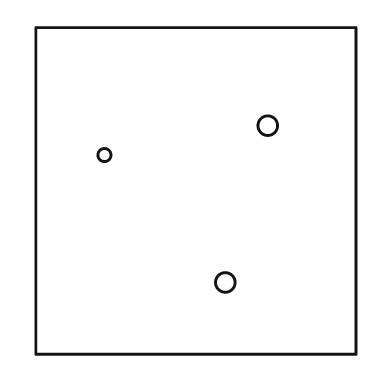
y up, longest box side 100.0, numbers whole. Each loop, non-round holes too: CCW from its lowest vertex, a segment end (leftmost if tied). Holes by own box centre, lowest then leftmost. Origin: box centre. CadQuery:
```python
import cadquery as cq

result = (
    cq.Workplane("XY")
    .moveTo(-49.0, -50.0)
    .lineTo(49.0, -50.0)
    .lineTo(49.0, 50.0)
    .lineTo(-49.0, 50.0)
    .close()
    .moveTo(9.0, -28.0)
    .circle(3.0)
    .moveTo(-28.0, 11.0)
    .circle(2.0)
    .moveTo(22.0, 20.0)
    .circle(3.0)
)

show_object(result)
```